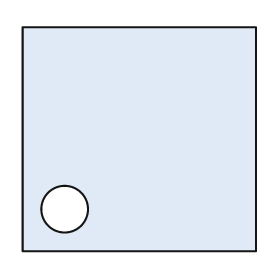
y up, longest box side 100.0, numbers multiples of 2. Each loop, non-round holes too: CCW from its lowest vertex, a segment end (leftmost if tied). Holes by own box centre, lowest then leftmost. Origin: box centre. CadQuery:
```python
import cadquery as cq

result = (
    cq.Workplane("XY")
    .moveTo(-50.0, -48.0)
    .lineTo(50.0, -48.0)
    .lineTo(50.0, 48.0)
    .lineTo(-50.0, 48.0)
    .close()
    .moveTo(-32.0, -30.0)
    .circle(10.0)
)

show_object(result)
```